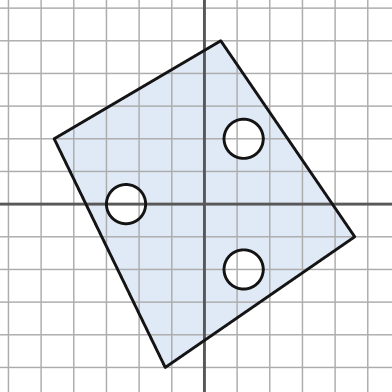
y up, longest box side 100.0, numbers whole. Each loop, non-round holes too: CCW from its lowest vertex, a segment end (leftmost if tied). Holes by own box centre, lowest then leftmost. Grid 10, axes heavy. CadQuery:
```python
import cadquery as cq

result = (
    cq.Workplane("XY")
    .moveTo(-12.0, -50.0)
    .lineTo(46.0, -10.0)
    .lineTo(5.0, 50.0)
    .lineTo(-46.0, 20.0)
    .close()
    .moveTo(12.0, -20.0)
    .circle(6.0)
    .moveTo(-24.0, 0.0)
    .circle(6.0)
    .moveTo(12.0, 20.0)
    .circle(6.0)
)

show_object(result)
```